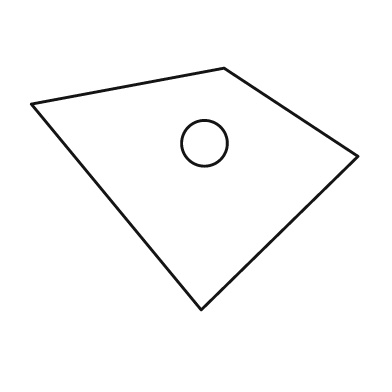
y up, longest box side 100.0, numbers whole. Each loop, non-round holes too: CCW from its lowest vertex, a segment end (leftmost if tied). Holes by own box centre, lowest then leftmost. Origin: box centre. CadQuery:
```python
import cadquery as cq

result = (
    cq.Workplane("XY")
    .moveTo(2.0, -37.0)
    .lineTo(50.0, 10.0)
    .lineTo(9.0, 37.0)
    .lineTo(-50.0, 26.0)
    .close()
    .moveTo(3.0, 14.0)
    .circle(7.0)
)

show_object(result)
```